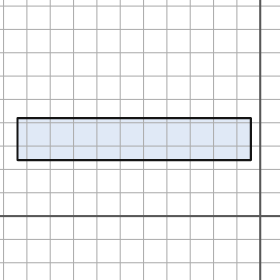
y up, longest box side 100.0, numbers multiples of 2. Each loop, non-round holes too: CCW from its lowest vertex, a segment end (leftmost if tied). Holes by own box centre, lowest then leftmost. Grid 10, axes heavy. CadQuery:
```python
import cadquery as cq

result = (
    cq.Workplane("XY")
    .moveTo(-104.0, 24.0)
    .lineTo(-4.0, 24.0)
    .lineTo(-4.0, 42.0)
    .lineTo(-104.0, 42.0)
    .close()
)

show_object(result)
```